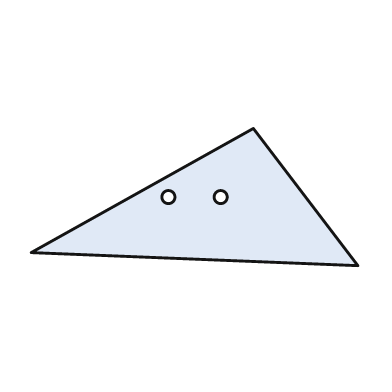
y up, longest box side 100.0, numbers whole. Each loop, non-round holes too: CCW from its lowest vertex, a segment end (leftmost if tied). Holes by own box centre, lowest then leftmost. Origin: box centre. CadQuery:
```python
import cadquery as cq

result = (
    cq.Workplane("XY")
    .moveTo(50.0, -21.0)
    .lineTo(18.0, 21.0)
    .lineTo(-50.0, -17.0)
    .close()
    .moveTo(-8.0, 0.0)
    .circle(2.0)
    .moveTo(8.0, 0.0)
    .circle(2.0)
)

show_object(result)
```